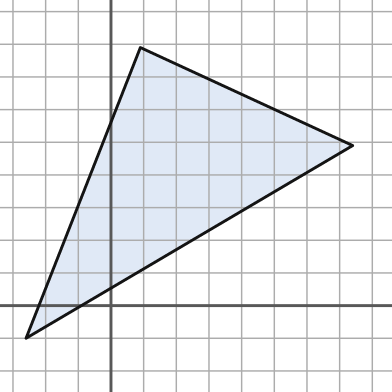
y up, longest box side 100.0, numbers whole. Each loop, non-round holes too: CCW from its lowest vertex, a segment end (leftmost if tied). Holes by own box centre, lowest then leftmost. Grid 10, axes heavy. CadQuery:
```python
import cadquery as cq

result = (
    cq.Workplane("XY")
    .moveTo(-26.0, -10.0)
    .lineTo(74.0, 49.0)
    .lineTo(9.0, 79.0)
    .close()
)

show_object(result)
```